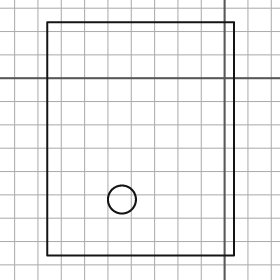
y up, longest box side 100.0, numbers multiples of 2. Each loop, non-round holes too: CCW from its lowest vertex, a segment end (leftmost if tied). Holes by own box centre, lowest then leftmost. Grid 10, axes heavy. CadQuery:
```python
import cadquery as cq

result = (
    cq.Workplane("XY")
    .moveTo(-76.0, -76.0)
    .lineTo(4.0, -76.0)
    .lineTo(4.0, 24.0)
    .lineTo(-76.0, 24.0)
    .close()
    .moveTo(-44.0, -52.0)
    .circle(6.0)
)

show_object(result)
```